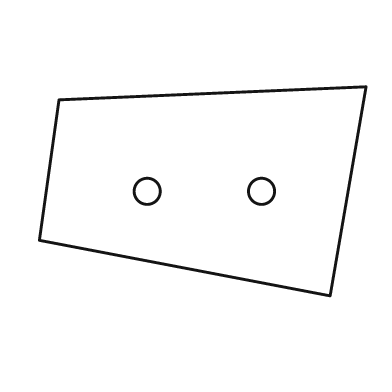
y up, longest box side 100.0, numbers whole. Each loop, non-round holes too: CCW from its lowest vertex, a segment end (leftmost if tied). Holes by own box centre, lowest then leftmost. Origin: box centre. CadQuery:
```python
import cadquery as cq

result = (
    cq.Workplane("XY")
    .moveTo(39.0, -32.0)
    .lineTo(50.0, 32.0)
    .lineTo(-44.0, 28.0)
    .lineTo(-50.0, -15.0)
    .close()
    .moveTo(-17.0, 0.0)
    .circle(4.0)
    .moveTo(18.0, 0.0)
    .circle(4.0)
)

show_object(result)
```